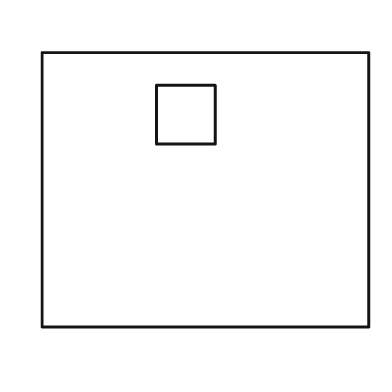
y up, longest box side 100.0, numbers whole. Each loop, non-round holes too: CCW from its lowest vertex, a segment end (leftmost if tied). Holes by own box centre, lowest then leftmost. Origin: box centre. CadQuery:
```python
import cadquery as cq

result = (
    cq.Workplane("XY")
    .moveTo(-50.0, -42.0)
    .lineTo(50.0, -42.0)
    .lineTo(50.0, 42.0)
    .lineTo(-50.0, 42.0)
    .close()
    .moveTo(-15.0, 14.0)
    .lineTo(3.0, 14.0)
    .lineTo(3.0, 32.0)
    .lineTo(-15.0, 32.0)
    .close()
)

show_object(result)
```